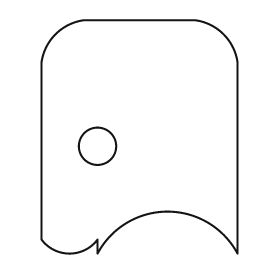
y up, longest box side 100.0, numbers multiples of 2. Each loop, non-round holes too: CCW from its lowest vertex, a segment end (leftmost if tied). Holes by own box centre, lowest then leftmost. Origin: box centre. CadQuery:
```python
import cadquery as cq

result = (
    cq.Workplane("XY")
    .moveTo(-18.0, -50.0)
    .threePointArc((12.0, -32.0), (42.0, -50.0))
    .lineTo(42.0, 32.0)
    .threePointArc((36.0, 44.0), (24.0, 50.0))
    .lineTo(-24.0, 50.0)
    .threePointArc((-36.0, 44.0), (-42.0, 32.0))
    .lineTo(-42.0, -44.0)
    .threePointArc((-30.0, -50.0), (-18.0, -44.0))
    .close()
    .moveTo(-18.0, -4.0)
    .circle(8.0)
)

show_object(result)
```